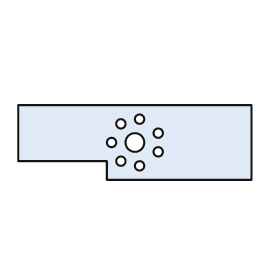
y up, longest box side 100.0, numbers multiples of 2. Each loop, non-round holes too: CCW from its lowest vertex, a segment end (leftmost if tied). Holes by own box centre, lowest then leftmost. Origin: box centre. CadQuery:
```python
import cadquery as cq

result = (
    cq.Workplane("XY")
    .moveTo(-12.0, -16.0)
    .lineTo(50.0, -16.0)
    .lineTo(50.0, 16.0)
    .lineTo(-50.0, 16.0)
    .lineTo(-50.0, -8.0)
    .lineTo(-12.0, -8.0)
    .close()
    .moveTo(2.0, -10.0)
    .circle(2.0)
    .moveTo(-6.0, -8.0)
    .circle(2.0)
    .moveTo(10.0, -4.0)
    .circle(2.0)
    .moveTo(-10.0, 0.0)
    .circle(2.0)
    .moveTo(0.0, 0.0)
    .circle(4.0)
    .moveTo(10.0, 4.0)
    .circle(2.0)
    .moveTo(-6.0, 8.0)
    .circle(2.0)
    .moveTo(2.0, 10.0)
    .circle(2.0)
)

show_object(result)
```